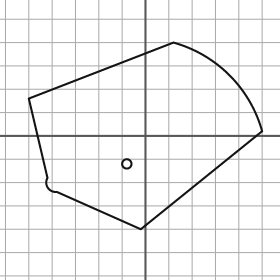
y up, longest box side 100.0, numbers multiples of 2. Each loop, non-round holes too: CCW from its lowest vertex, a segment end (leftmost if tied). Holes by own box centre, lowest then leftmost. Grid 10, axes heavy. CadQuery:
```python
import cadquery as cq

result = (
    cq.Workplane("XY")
    .moveTo(-2.0, -40.0)
    .lineTo(50.0, 2.0)
    .threePointArc((36.0, 26.0), (12.0, 40.0))
    .lineTo(-50.0, 16.0)
    .lineTo(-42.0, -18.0)
    .threePointArc((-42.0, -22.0), (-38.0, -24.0))
    .close()
    .moveTo(-8.0, -12.0)
    .circle(2.0)
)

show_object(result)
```